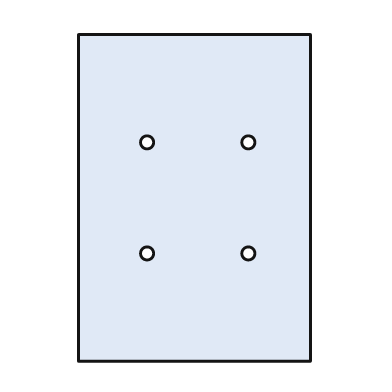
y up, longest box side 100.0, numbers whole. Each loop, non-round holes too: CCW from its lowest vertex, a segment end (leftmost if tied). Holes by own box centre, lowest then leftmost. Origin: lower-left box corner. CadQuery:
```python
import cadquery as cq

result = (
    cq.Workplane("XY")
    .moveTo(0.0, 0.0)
    .lineTo(71.0, 0.0)
    .lineTo(71.0, 100.0)
    .lineTo(0.0, 100.0)
    .close()
    .moveTo(21.0, 33.0)
    .circle(2.0)
    .moveTo(52.0, 33.0)
    .circle(2.0)
    .moveTo(21.0, 67.0)
    .circle(2.0)
    .moveTo(52.0, 67.0)
    .circle(2.0)
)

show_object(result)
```